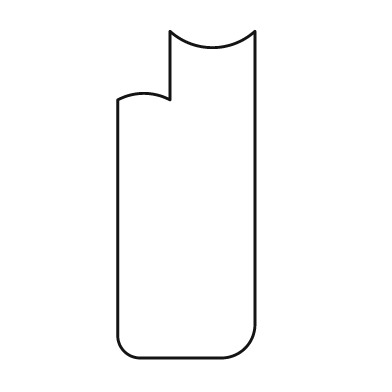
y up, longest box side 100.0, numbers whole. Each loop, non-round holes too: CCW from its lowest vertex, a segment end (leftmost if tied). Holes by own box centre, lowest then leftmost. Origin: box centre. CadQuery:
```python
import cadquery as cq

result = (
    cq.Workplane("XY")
    .moveTo(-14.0, -50.0)
    .lineTo(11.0, -50.0)
    .threePointArc((18.0, -47.0), (21.0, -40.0))
    .lineTo(21.0, 50.0)
    .threePointArc((8.0, 45.0), (-5.0, 50.0))
    .lineTo(-5.0, 29.0)
    .threePointArc((-13.0, 31.0), (-21.0, 29.0))
    .lineTo(-21.0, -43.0)
    .threePointArc((-19.0, -48.0), (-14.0, -50.0))
    .close()
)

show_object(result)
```